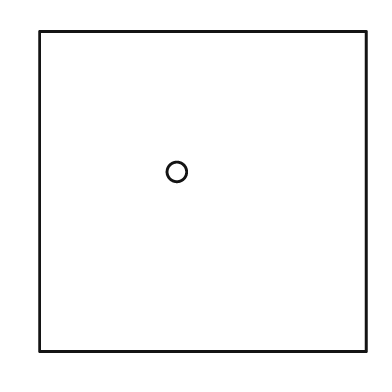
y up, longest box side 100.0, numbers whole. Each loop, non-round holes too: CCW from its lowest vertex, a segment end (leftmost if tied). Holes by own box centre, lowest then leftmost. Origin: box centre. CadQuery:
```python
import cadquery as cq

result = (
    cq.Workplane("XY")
    .moveTo(-50.0, -49.0)
    .lineTo(50.0, -49.0)
    .lineTo(50.0, 49.0)
    .lineTo(-50.0, 49.0)
    .close()
    .moveTo(-8.0, 6.0)
    .circle(3.0)
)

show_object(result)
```